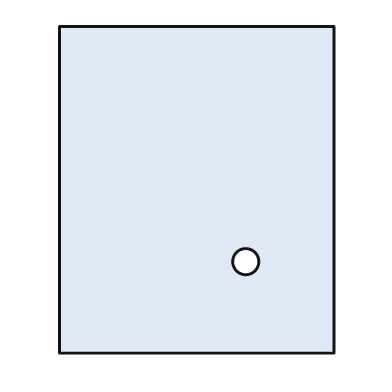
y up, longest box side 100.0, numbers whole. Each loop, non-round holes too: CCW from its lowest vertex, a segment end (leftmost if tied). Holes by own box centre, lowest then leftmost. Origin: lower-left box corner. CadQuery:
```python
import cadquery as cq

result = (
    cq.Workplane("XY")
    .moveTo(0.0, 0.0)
    .lineTo(84.0, 0.0)
    .lineTo(84.0, 100.0)
    .lineTo(0.0, 100.0)
    .close()
    .moveTo(57.0, 28.0)
    .circle(4.0)
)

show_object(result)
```